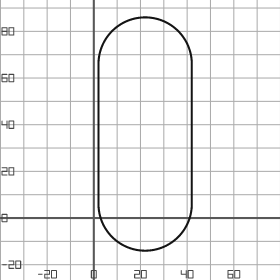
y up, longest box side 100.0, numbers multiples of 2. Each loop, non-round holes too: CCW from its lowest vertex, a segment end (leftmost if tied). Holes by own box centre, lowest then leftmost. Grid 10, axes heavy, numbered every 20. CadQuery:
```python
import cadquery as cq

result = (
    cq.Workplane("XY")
    .moveTo(2.0, 6.0)
    .threePointArc((22.0, -14.0), (42.0, 6.0))
    .lineTo(42.0, 66.0)
    .threePointArc((22.0, 86.0), (2.0, 66.0))
    .close()
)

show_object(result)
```